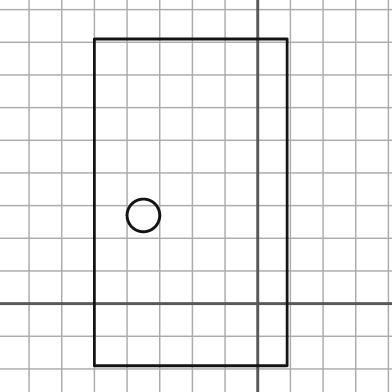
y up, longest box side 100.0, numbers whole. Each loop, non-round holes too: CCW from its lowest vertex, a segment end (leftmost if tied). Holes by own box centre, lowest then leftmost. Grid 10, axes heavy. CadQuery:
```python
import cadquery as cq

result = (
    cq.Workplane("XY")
    .moveTo(-50.0, -19.0)
    .lineTo(9.0, -19.0)
    .lineTo(9.0, 81.0)
    .lineTo(-50.0, 81.0)
    .close()
    .moveTo(-35.0, 27.0)
    .circle(5.0)
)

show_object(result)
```